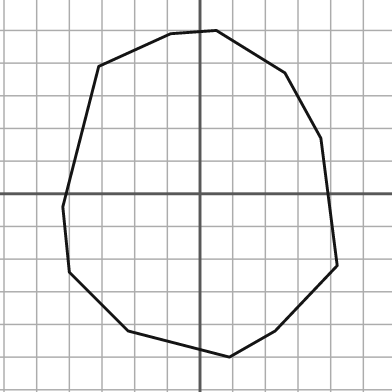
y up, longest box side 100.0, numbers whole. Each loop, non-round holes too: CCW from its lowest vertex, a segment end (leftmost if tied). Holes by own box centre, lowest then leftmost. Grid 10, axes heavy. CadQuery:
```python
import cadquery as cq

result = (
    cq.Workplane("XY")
    .moveTo(9.0, -50.0)
    .lineTo(23.0, -42.0)
    .lineTo(42.0, -22.0)
    .lineTo(37.0, 17.0)
    .lineTo(26.0, 37.0)
    .lineTo(5.0, 50.0)
    .lineTo(-9.0, 49.0)
    .lineTo(-31.0, 39.0)
    .lineTo(-42.0, -4.0)
    .lineTo(-40.0, -24.0)
    .lineTo(-22.0, -42.0)
    .close()
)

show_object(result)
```